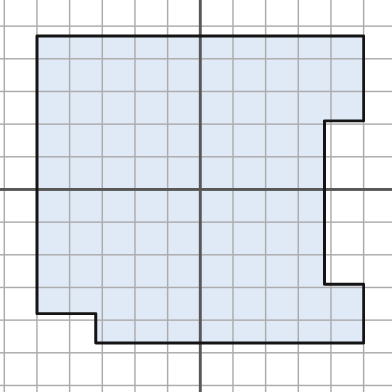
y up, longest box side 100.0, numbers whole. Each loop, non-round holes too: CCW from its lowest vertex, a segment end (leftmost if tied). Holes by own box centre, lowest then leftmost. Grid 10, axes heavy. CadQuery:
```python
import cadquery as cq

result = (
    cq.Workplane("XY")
    .moveTo(-32.0, -47.0)
    .lineTo(50.0, -47.0)
    .lineTo(50.0, -29.0)
    .lineTo(38.0, -29.0)
    .lineTo(38.0, 21.0)
    .lineTo(50.0, 21.0)
    .lineTo(50.0, 47.0)
    .lineTo(-50.0, 47.0)
    .lineTo(-50.0, -38.0)
    .lineTo(-32.0, -38.0)
    .close()
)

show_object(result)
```